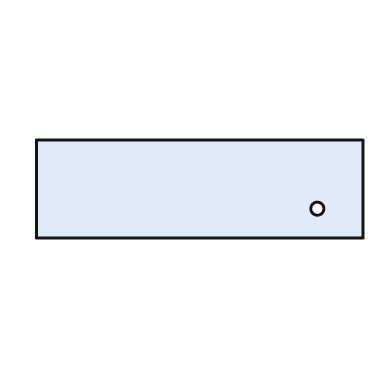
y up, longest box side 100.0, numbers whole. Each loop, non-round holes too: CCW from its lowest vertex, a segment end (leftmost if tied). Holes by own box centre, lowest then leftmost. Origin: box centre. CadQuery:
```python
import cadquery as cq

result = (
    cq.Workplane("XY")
    .moveTo(-50.0, -15.0)
    .lineTo(50.0, -15.0)
    .lineTo(50.0, 15.0)
    .lineTo(-50.0, 15.0)
    .close()
    .moveTo(36.0, -6.0)
    .circle(2.0)
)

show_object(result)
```